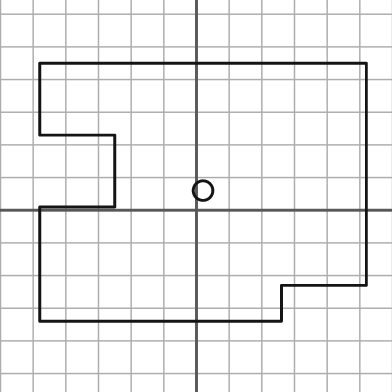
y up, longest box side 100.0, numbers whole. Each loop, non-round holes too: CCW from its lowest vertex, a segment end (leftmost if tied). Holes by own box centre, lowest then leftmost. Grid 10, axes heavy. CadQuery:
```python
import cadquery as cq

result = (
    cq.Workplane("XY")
    .moveTo(-48.0, -34.0)
    .lineTo(26.0, -34.0)
    .lineTo(26.0, -23.0)
    .lineTo(52.0, -23.0)
    .lineTo(52.0, 45.0)
    .lineTo(-48.0, 45.0)
    .lineTo(-48.0, 23.0)
    .lineTo(-25.0, 23.0)
    .lineTo(-25.0, 1.0)
    .lineTo(-48.0, 1.0)
    .close()
    .moveTo(2.0, 6.0)
    .circle(3.0)
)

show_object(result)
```